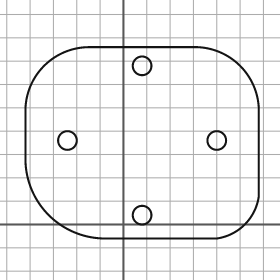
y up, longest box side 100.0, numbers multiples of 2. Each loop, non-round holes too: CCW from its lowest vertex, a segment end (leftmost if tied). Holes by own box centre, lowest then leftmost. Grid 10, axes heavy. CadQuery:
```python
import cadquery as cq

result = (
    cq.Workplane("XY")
    .moveTo(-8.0, -6.0)
    .lineTo(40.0, -6.0)
    .threePointArc((52.0, 0.0), (58.0, 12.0))
    .lineTo(58.0, 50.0)
    .threePointArc((50.0, 68.0), (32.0, 76.0))
    .lineTo(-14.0, 76.0)
    .threePointArc((-34.0, 68.0), (-42.0, 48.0))
    .lineTo(-42.0, 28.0)
    .threePointArc((-32.0, 4.0), (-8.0, -6.0))
    .close()
    .moveTo(8.0, 4.0)
    .circle(4.0)
    .moveTo(-24.0, 36.0)
    .circle(4.0)
    .moveTo(40.0, 36.0)
    .circle(4.0)
    .moveTo(8.0, 68.0)
    .circle(4.0)
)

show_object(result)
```